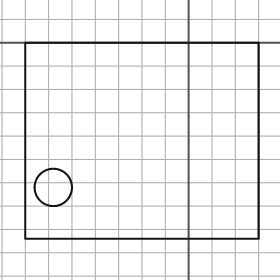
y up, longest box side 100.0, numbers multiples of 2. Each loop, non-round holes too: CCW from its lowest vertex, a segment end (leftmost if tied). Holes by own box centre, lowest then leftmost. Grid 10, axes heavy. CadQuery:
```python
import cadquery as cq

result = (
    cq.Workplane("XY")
    .moveTo(-70.0, -84.0)
    .lineTo(30.0, -84.0)
    .lineTo(30.0, 0.0)
    .lineTo(-70.0, 0.0)
    .close()
    .moveTo(-58.0, -62.0)
    .circle(8.0)
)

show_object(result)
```